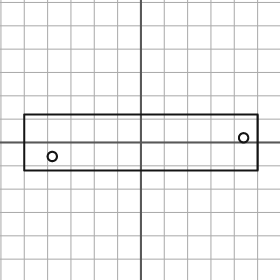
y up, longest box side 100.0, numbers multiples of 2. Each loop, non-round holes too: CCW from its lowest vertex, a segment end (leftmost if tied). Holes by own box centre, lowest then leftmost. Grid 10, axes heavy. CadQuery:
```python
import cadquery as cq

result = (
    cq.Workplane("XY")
    .moveTo(-50.0, -12.0)
    .lineTo(50.0, -12.0)
    .lineTo(50.0, 12.0)
    .lineTo(-50.0, 12.0)
    .close()
    .moveTo(-38.0, -6.0)
    .circle(2.0)
    .moveTo(44.0, 2.0)
    .circle(2.0)
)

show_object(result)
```